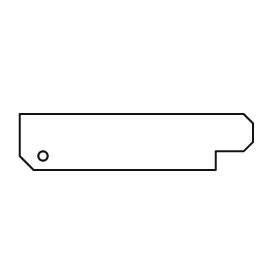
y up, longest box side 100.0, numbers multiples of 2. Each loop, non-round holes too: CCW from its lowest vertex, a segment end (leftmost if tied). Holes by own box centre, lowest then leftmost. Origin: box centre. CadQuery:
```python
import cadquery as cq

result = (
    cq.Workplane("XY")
    .moveTo(-44.0, -12.0)
    .lineTo(34.0, -12.0)
    .lineTo(34.0, -4.0)
    .lineTo(46.0, -4.0)
    .lineTo(50.0, 0.0)
    .lineTo(50.0, 8.0)
    .lineTo(46.0, 12.0)
    .lineTo(-50.0, 12.0)
    .lineTo(-50.0, -6.0)
    .close()
    .moveTo(-40.0, -6.0)
    .circle(2.0)
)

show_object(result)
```